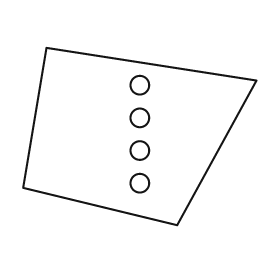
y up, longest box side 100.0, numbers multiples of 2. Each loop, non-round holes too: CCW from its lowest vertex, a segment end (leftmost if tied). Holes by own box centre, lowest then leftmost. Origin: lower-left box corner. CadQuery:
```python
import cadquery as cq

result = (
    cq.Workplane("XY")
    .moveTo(66.0, 0.0)
    .lineTo(100.0, 62.0)
    .lineTo(10.0, 76.0)
    .lineTo(0.0, 16.0)
    .close()
    .moveTo(50.0, 18.0)
    .circle(4.0)
    .moveTo(50.0, 32.0)
    .circle(4.0)
    .moveTo(50.0, 46.0)
    .circle(4.0)
    .moveTo(50.0, 60.0)
    .circle(4.0)
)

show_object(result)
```